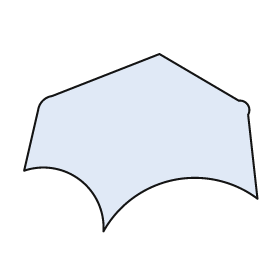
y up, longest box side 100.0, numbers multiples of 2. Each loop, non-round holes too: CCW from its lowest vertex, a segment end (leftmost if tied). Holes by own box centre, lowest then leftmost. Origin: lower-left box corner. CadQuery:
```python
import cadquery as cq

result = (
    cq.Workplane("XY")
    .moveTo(34.0, 0.0)
    .threePointArc((64.0, 22.0), (100.0, 14.0))
    .lineTo(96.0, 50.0)
    .threePointArc((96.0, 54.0), (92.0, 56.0))
    .lineTo(58.0, 76.0)
    .lineTo(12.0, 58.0)
    .threePointArc((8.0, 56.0), (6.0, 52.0))
    .lineTo(0.0, 26.0)
    .threePointArc((24.0, 22.0), (34.0, 0.0))
    .close()
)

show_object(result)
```